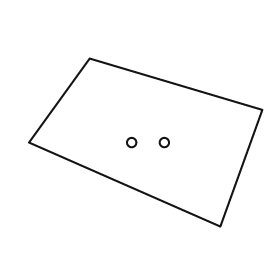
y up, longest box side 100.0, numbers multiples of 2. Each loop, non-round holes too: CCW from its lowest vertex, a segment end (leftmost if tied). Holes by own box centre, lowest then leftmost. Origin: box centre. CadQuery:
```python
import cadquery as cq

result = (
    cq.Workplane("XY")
    .moveTo(32.0, -36.0)
    .lineTo(50.0, 14.0)
    .lineTo(-24.0, 36.0)
    .lineTo(-50.0, 0.0)
    .close()
    .moveTo(-6.0, 0.0)
    .circle(2.0)
    .moveTo(8.0, 0.0)
    .circle(2.0)
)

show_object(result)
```